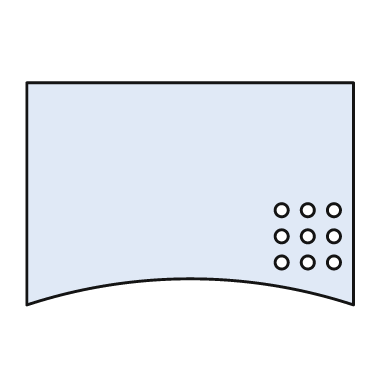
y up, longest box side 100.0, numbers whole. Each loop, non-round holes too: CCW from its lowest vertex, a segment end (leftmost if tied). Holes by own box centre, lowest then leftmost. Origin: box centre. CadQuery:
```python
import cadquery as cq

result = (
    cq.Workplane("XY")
    .moveTo(-50.0, -34.0)
    .threePointArc((0.0, -26.0), (50.0, -34.0))
    .lineTo(50.0, 34.0)
    .lineTo(-50.0, 34.0)
    .close()
    .moveTo(28.0, -21.0)
    .circle(2.0)
    .moveTo(36.0, -21.0)
    .circle(2.0)
    .moveTo(44.0, -21.0)
    .circle(2.0)
    .moveTo(28.0, -13.0)
    .circle(2.0)
    .moveTo(36.0, -13.0)
    .circle(2.0)
    .moveTo(44.0, -13.0)
    .circle(2.0)
    .moveTo(28.0, -5.0)
    .circle(2.0)
    .moveTo(36.0, -5.0)
    .circle(2.0)
    .moveTo(44.0, -5.0)
    .circle(2.0)
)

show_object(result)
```